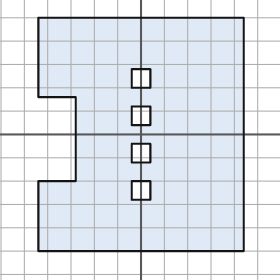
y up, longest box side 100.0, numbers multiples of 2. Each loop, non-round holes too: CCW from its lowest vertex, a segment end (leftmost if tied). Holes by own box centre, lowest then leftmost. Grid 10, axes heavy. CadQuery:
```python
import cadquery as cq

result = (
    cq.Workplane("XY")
    .moveTo(-44.0, -50.0)
    .lineTo(44.0, -50.0)
    .lineTo(44.0, 50.0)
    .lineTo(-44.0, 50.0)
    .lineTo(-44.0, 16.0)
    .lineTo(-28.0, 16.0)
    .lineTo(-28.0, -20.0)
    .lineTo(-44.0, -20.0)
    .close()
    .moveTo(-4.0, -28.0)
    .lineTo(4.0, -28.0)
    .lineTo(4.0, -20.0)
    .lineTo(-4.0, -20.0)
    .close()
    .moveTo(-4.0, -12.0)
    .lineTo(4.0, -12.0)
    .lineTo(4.0, -4.0)
    .lineTo(-4.0, -4.0)
    .close()
    .moveTo(-4.0, 4.0)
    .lineTo(4.0, 4.0)
    .lineTo(4.0, 12.0)
    .lineTo(-4.0, 12.0)
    .close()
    .moveTo(-4.0, 20.0)
    .lineTo(4.0, 20.0)
    .lineTo(4.0, 28.0)
    .lineTo(-4.0, 28.0)
    .close()
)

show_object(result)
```